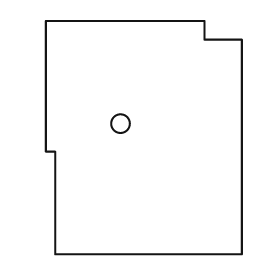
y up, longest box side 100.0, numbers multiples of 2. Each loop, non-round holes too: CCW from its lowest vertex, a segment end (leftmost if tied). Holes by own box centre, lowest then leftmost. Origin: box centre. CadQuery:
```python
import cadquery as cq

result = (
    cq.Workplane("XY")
    .moveTo(-38.0, -50.0)
    .lineTo(42.0, -50.0)
    .lineTo(42.0, 42.0)
    .lineTo(26.0, 42.0)
    .lineTo(26.0, 50.0)
    .lineTo(-42.0, 50.0)
    .lineTo(-42.0, -6.0)
    .lineTo(-38.0, -6.0)
    .close()
    .moveTo(-10.0, 6.0)
    .circle(4.0)
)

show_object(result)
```